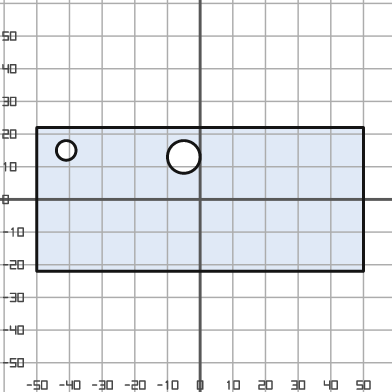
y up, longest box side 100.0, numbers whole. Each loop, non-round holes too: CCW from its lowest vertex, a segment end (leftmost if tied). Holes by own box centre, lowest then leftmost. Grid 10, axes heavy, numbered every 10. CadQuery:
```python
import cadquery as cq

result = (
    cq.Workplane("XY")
    .moveTo(-50.0, -22.0)
    .lineTo(50.0, -22.0)
    .lineTo(50.0, 22.0)
    .lineTo(-50.0, 22.0)
    .close()
    .moveTo(-5.0, 13.0)
    .circle(5.0)
    .moveTo(-41.0, 15.0)
    .circle(3.0)
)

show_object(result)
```